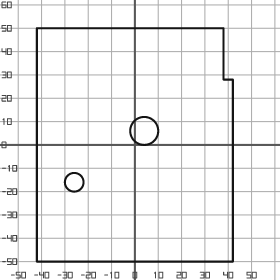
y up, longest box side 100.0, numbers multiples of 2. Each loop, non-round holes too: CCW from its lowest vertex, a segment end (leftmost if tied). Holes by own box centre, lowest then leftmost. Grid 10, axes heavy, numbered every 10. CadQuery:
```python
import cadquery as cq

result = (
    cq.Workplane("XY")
    .moveTo(-42.0, -50.0)
    .lineTo(42.0, -50.0)
    .lineTo(42.0, 28.0)
    .lineTo(38.0, 28.0)
    .lineTo(38.0, 50.0)
    .lineTo(-42.0, 50.0)
    .close()
    .moveTo(-26.0, -16.0)
    .circle(4.0)
    .moveTo(4.0, 6.0)
    .circle(6.0)
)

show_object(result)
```